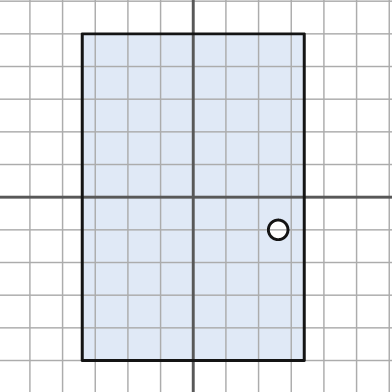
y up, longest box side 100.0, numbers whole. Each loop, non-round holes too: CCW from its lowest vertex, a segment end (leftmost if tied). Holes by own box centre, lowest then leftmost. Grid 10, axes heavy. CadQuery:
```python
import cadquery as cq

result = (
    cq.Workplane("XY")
    .moveTo(-34.0, -50.0)
    .lineTo(34.0, -50.0)
    .lineTo(34.0, 50.0)
    .lineTo(-34.0, 50.0)
    .close()
    .moveTo(26.0, -10.0)
    .circle(3.0)
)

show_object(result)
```